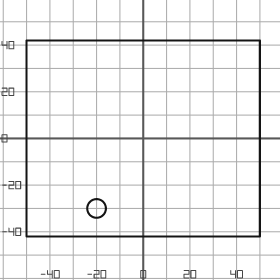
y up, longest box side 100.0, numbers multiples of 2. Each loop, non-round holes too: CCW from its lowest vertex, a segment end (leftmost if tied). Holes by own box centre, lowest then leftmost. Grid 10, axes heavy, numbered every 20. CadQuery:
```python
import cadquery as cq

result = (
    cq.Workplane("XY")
    .moveTo(-50.0, -42.0)
    .lineTo(50.0, -42.0)
    .lineTo(50.0, 42.0)
    .lineTo(-50.0, 42.0)
    .close()
    .moveTo(-20.0, -30.0)
    .circle(4.0)
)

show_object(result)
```